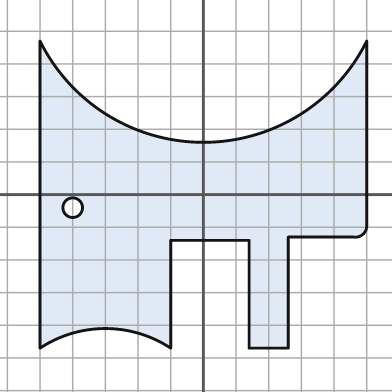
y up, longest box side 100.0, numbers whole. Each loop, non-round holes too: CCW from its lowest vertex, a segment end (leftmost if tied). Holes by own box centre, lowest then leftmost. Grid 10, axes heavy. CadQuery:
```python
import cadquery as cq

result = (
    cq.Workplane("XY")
    .moveTo(-50.0, -47.0)
    .threePointArc((-30.0, -41.0), (-10.0, -47.0))
    .lineTo(-10.0, -14.0)
    .lineTo(14.0, -14.0)
    .lineTo(14.0, -47.0)
    .lineTo(26.0, -47.0)
    .lineTo(26.0, -13.0)
    .lineTo(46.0, -13.0)
    .threePointArc((49.0, -12.0), (50.0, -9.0))
    .lineTo(50.0, 47.0)
    .threePointArc((0.0, 16.0), (-50.0, 47.0))
    .close()
    .moveTo(-40.0, -4.0)
    .circle(3.0)
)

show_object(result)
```